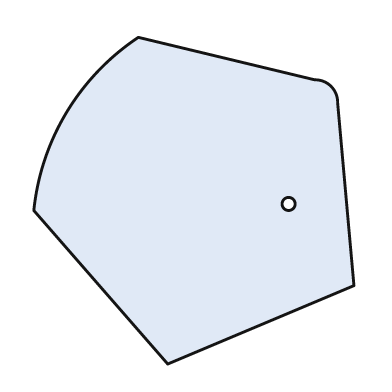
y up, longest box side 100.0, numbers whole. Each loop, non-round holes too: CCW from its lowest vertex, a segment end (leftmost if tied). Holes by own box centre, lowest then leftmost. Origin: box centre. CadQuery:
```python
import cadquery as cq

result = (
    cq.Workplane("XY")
    .moveTo(-8.0, -50.0)
    .lineTo(49.0, -26.0)
    .lineTo(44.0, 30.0)
    .threePointArc((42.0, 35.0), (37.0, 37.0))
    .lineTo(-17.0, 50.0)
    .threePointArc((-39.0, 27.0), (-49.0, -3.0))
    .close()
    .moveTo(29.0, -1.0)
    .circle(2.0)
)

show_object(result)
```